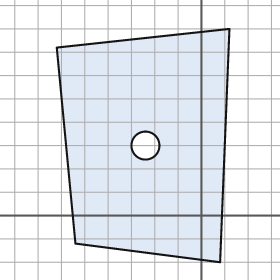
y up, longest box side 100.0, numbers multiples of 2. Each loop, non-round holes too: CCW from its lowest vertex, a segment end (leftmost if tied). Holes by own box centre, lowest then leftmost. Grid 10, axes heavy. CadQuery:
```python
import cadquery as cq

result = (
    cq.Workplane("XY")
    .moveTo(8.0, -20.0)
    .lineTo(12.0, 80.0)
    .lineTo(-62.0, 72.0)
    .lineTo(-54.0, -12.0)
    .close()
    .moveTo(-24.0, 30.0)
    .circle(6.0)
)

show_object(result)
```